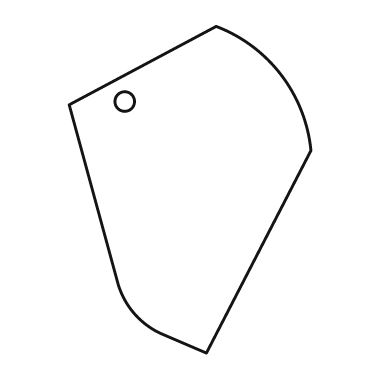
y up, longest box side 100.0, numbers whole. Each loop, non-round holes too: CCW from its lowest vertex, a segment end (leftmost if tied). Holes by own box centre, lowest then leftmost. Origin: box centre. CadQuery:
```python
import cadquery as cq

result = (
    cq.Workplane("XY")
    .moveTo(5.0, -50.0)
    .lineTo(37.0, 12.0)
    .threePointArc((28.0, 35.0), (8.0, 50.0))
    .lineTo(-37.0, 26.0)
    .lineTo(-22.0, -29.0)
    .threePointArc((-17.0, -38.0), (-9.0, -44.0))
    .close()
    .moveTo(-20.0, 27.0)
    .circle(3.0)
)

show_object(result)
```